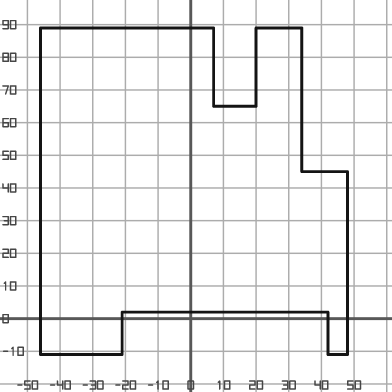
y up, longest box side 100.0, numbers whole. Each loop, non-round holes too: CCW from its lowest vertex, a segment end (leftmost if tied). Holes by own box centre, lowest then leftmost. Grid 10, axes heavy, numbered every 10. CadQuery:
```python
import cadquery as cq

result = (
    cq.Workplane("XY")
    .moveTo(-46.0, -11.0)
    .lineTo(-21.0, -11.0)
    .lineTo(-21.0, 2.0)
    .lineTo(42.0, 2.0)
    .lineTo(42.0, -11.0)
    .lineTo(48.0, -11.0)
    .lineTo(48.0, 45.0)
    .lineTo(34.0, 45.0)
    .lineTo(34.0, 89.0)
    .lineTo(20.0, 89.0)
    .lineTo(20.0, 65.0)
    .lineTo(7.0, 65.0)
    .lineTo(7.0, 89.0)
    .lineTo(-46.0, 89.0)
    .close()
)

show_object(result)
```